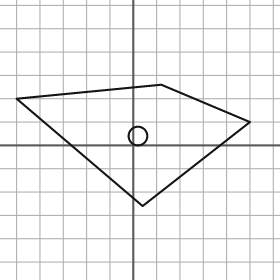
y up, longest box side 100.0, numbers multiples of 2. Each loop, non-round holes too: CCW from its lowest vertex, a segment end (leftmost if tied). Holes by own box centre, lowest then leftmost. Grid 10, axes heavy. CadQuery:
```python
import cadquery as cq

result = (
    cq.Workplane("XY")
    .moveTo(4.0, -26.0)
    .lineTo(50.0, 10.0)
    .lineTo(12.0, 26.0)
    .lineTo(-50.0, 20.0)
    .close()
    .moveTo(2.0, 4.0)
    .circle(4.0)
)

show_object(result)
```